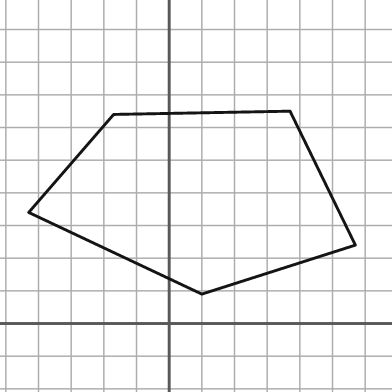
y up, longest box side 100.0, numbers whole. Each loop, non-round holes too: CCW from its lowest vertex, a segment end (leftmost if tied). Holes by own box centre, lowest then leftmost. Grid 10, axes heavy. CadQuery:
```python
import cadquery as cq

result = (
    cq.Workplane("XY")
    .moveTo(10.0, 9.0)
    .lineTo(57.0, 24.0)
    .lineTo(37.0, 65.0)
    .lineTo(-17.0, 64.0)
    .lineTo(-43.0, 34.0)
    .close()
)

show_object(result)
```